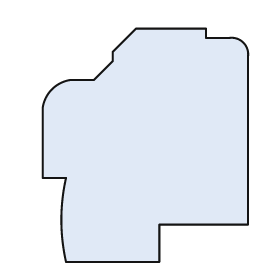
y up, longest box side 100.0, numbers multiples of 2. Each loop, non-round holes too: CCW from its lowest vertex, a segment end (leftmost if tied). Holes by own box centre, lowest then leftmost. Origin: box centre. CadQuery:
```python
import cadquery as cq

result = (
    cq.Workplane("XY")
    .moveTo(-34.0, -50.0)
    .lineTo(6.0, -50.0)
    .lineTo(6.0, -34.0)
    .lineTo(44.0, -34.0)
    .lineTo(44.0, 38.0)
    .threePointArc((42.0, 44.0), (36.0, 46.0))
    .lineTo(26.0, 46.0)
    .lineTo(26.0, 50.0)
    .lineTo(-4.0, 50.0)
    .lineTo(-14.0, 40.0)
    .lineTo(-14.0, 36.0)
    .lineTo(-22.0, 28.0)
    .lineTo(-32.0, 28.0)
    .threePointArc((-40.0, 24.0), (-44.0, 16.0))
    .lineTo(-44.0, -14.0)
    .lineTo(-34.0, -14.0)
    .threePointArc((-36.0, -32.0), (-34.0, -50.0))
    .close()
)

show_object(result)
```